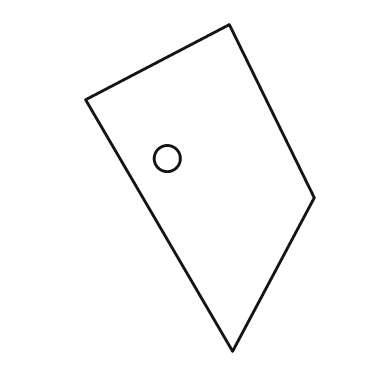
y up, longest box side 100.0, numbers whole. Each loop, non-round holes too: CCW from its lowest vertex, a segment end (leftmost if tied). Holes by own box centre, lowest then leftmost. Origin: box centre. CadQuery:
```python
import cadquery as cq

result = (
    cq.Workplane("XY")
    .moveTo(10.0, -50.0)
    .lineTo(35.0, -3.0)
    .lineTo(9.0, 50.0)
    .lineTo(-35.0, 27.0)
    .close()
    .moveTo(-10.0, 9.0)
    .circle(4.0)
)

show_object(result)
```